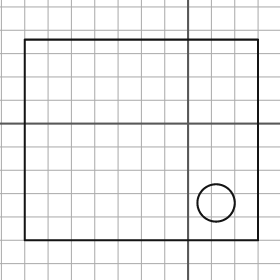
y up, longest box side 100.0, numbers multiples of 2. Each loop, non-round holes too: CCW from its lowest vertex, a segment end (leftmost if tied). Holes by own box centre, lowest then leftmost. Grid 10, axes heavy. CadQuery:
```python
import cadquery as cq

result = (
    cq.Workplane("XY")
    .moveTo(-70.0, -50.0)
    .lineTo(30.0, -50.0)
    .lineTo(30.0, 36.0)
    .lineTo(-70.0, 36.0)
    .close()
    .moveTo(12.0, -34.0)
    .circle(8.0)
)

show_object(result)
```